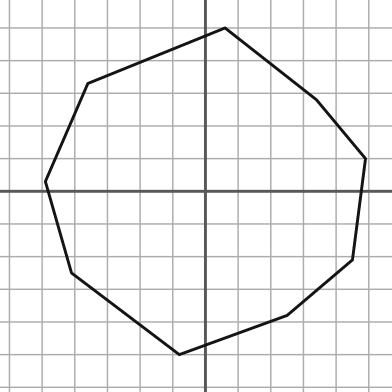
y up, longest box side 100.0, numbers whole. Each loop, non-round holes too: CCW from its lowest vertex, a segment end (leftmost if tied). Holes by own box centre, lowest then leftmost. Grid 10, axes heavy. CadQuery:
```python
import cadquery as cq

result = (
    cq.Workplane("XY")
    .moveTo(-8.0, -50.0)
    .lineTo(25.0, -38.0)
    .lineTo(45.0, -21.0)
    .lineTo(49.0, 10.0)
    .lineTo(34.0, 28.0)
    .lineTo(6.0, 50.0)
    .lineTo(-36.0, 33.0)
    .lineTo(-49.0, 3.0)
    .lineTo(-41.0, -25.0)
    .close()
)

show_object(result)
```